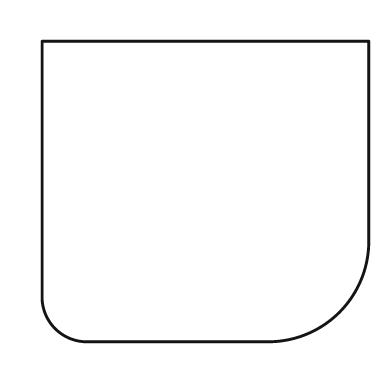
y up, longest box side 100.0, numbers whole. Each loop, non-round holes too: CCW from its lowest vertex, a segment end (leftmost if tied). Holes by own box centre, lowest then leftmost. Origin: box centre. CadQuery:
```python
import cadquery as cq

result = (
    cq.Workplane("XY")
    .moveTo(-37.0, -46.0)
    .lineTo(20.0, -46.0)
    .threePointArc((41.0, -37.0), (50.0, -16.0))
    .lineTo(50.0, 46.0)
    .lineTo(-50.0, 46.0)
    .lineTo(-50.0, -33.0)
    .threePointArc((-46.0, -42.0), (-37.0, -46.0))
    .close()
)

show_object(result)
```